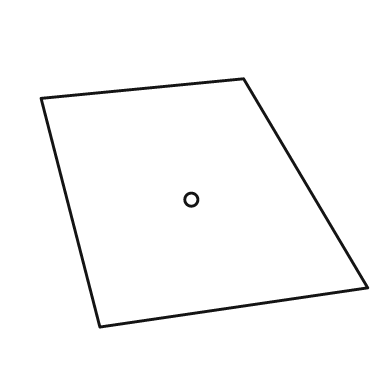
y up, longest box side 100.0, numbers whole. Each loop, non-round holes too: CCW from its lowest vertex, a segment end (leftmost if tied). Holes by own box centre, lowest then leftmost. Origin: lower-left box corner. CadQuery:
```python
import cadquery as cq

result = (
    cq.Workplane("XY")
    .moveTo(18.0, 0.0)
    .lineTo(100.0, 12.0)
    .lineTo(62.0, 76.0)
    .lineTo(0.0, 70.0)
    .close()
    .moveTo(46.0, 39.0)
    .circle(2.0)
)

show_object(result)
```